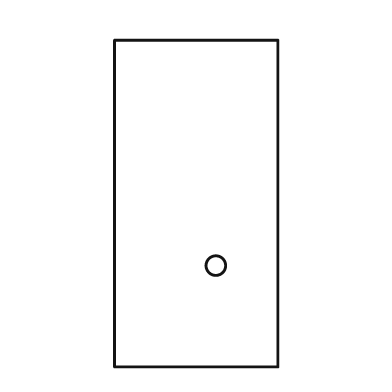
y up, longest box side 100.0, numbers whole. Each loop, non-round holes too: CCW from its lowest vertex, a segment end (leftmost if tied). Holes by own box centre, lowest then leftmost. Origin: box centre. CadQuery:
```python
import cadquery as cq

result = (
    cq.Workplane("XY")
    .moveTo(-25.0, -50.0)
    .lineTo(25.0, -50.0)
    .lineTo(25.0, 50.0)
    .lineTo(-25.0, 50.0)
    .close()
    .moveTo(6.0, -19.0)
    .circle(3.0)
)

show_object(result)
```